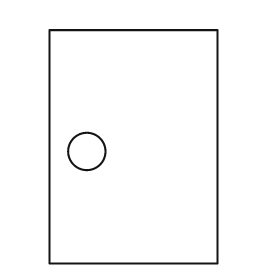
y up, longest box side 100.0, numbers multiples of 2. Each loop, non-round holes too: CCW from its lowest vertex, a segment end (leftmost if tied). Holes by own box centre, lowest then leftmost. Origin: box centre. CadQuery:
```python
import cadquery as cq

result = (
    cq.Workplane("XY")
    .moveTo(-36.0, -50.0)
    .lineTo(36.0, -50.0)
    .lineTo(36.0, 50.0)
    .lineTo(-36.0, 50.0)
    .close()
    .moveTo(-20.0, -2.0)
    .circle(8.0)
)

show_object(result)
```